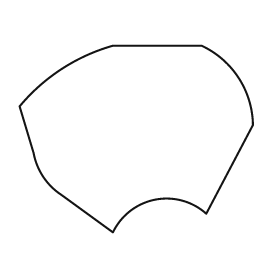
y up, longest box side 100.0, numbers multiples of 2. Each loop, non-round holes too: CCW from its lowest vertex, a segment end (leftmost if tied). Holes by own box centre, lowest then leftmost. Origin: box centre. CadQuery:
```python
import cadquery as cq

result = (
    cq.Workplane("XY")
    .moveTo(-10.0, -40.0)
    .threePointArc((8.0, -26.0), (30.0, -32.0))
    .lineTo(50.0, 6.0)
    .threePointArc((44.0, 26.0), (28.0, 40.0))
    .lineTo(-10.0, 40.0)
    .threePointArc((-32.0, 30.0), (-50.0, 14.0))
    .lineTo(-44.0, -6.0)
    .threePointArc((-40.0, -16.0), (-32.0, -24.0))
    .close()
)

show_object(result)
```